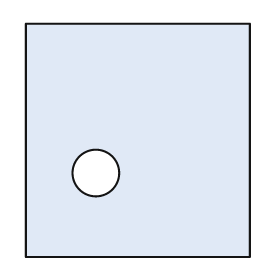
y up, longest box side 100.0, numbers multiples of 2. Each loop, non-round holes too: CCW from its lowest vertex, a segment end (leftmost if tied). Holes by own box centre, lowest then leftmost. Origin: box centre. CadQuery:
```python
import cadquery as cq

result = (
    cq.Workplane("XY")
    .moveTo(-48.0, -50.0)
    .lineTo(48.0, -50.0)
    .lineTo(48.0, 50.0)
    .lineTo(-48.0, 50.0)
    .close()
    .moveTo(-18.0, -14.0)
    .circle(10.0)
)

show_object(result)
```